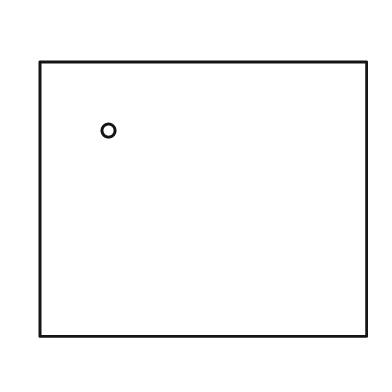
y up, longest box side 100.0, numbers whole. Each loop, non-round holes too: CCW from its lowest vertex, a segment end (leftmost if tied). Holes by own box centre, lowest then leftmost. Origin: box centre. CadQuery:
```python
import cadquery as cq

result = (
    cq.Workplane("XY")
    .moveTo(-50.0, -42.0)
    .lineTo(50.0, -42.0)
    .lineTo(50.0, 42.0)
    .lineTo(-50.0, 42.0)
    .close()
    .moveTo(-29.0, 21.0)
    .circle(2.0)
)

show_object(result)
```